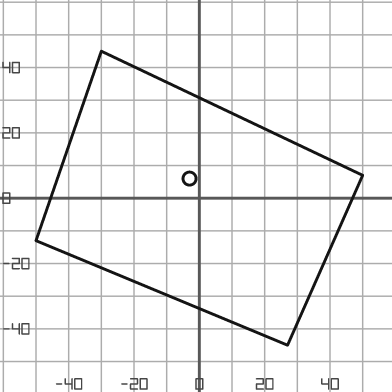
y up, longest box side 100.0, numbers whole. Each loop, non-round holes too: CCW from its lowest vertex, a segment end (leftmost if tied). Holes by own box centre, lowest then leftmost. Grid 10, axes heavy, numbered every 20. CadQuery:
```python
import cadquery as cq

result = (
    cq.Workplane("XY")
    .moveTo(27.0, -45.0)
    .lineTo(50.0, 7.0)
    .lineTo(-30.0, 45.0)
    .lineTo(-50.0, -13.0)
    .close()
    .moveTo(-3.0, 6.0)
    .circle(2.0)
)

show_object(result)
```